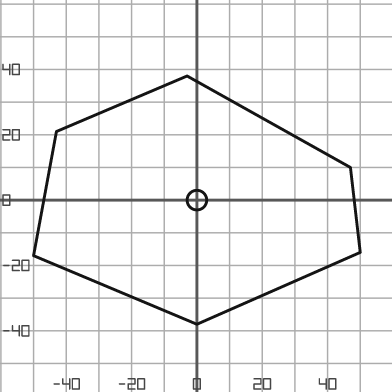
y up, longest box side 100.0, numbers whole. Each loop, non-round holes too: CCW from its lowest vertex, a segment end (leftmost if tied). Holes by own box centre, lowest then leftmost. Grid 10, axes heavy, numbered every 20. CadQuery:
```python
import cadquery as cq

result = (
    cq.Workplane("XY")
    .moveTo(0.0, -38.0)
    .lineTo(50.0, -16.0)
    .lineTo(47.0, 10.0)
    .lineTo(-3.0, 38.0)
    .lineTo(-43.0, 21.0)
    .lineTo(-50.0, -17.0)
    .close()
    .moveTo(0.0, 0.0)
    .circle(3.0)
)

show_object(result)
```